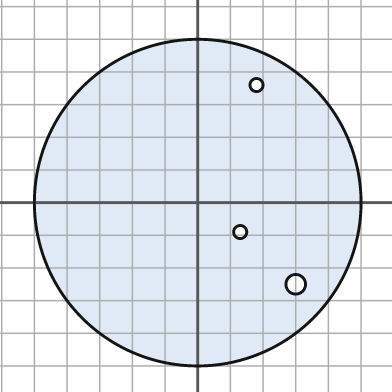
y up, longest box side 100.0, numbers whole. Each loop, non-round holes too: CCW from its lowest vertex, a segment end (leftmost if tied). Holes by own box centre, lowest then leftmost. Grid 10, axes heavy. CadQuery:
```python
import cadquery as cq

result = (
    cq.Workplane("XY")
    .moveTo(0.0, 0.0)
    .circle(50.0)
    .moveTo(30.0, -25.0)
    .circle(3.0)
    .moveTo(13.0, -9.0)
    .circle(2.0)
    .moveTo(18.0, 36.0)
    .circle(2.0)
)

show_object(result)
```